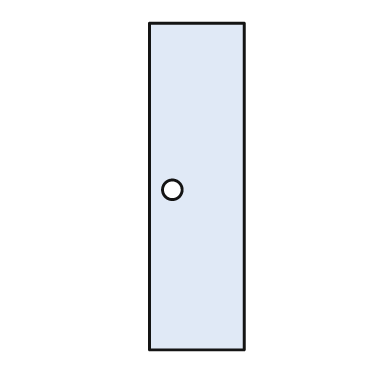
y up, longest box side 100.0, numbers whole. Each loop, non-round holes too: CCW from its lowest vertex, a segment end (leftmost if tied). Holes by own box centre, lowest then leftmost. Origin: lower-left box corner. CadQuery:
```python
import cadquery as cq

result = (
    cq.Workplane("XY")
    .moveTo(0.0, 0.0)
    .lineTo(29.0, 0.0)
    .lineTo(29.0, 100.0)
    .lineTo(0.0, 100.0)
    .close()
    .moveTo(7.0, 49.0)
    .circle(3.0)
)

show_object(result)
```